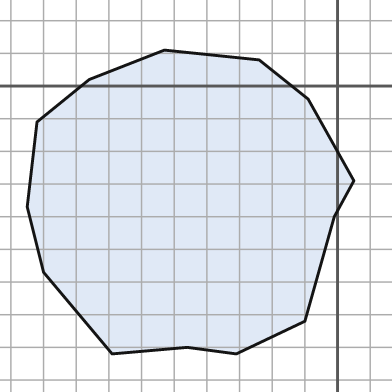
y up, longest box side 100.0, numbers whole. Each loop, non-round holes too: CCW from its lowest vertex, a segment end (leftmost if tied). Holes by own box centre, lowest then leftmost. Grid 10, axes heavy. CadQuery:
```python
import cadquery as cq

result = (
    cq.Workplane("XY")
    .moveTo(-69.0, -82.0)
    .lineTo(-46.0, -80.0)
    .lineTo(-31.0, -82.0)
    .lineTo(-10.0, -72.0)
    .lineTo(-1.0, -40.0)
    .lineTo(5.0, -29.0)
    .lineTo(-9.0, -4.0)
    .lineTo(-24.0, 8.0)
    .lineTo(-53.0, 11.0)
    .lineTo(-76.0, 2.0)
    .lineTo(-92.0, -11.0)
    .lineTo(-95.0, -37.0)
    .lineTo(-90.0, -57.0)
    .close()
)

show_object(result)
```